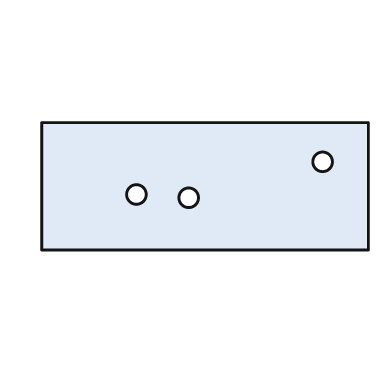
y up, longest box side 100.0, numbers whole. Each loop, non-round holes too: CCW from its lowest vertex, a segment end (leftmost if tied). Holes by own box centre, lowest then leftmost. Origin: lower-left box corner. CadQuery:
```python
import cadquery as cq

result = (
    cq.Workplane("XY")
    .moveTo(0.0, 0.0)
    .lineTo(100.0, 0.0)
    .lineTo(100.0, 39.0)
    .lineTo(0.0, 39.0)
    .close()
    .moveTo(45.0, 16.0)
    .circle(3.0)
    .moveTo(29.0, 17.0)
    .circle(3.0)
    .moveTo(86.0, 27.0)
    .circle(3.0)
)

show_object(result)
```